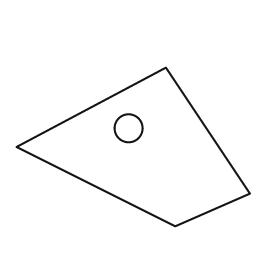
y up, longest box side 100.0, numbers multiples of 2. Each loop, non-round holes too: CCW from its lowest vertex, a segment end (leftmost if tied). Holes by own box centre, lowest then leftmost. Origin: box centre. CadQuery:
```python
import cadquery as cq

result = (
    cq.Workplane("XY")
    .moveTo(18.0, -34.0)
    .lineTo(50.0, -20.0)
    .lineTo(14.0, 34.0)
    .lineTo(-50.0, 0.0)
    .close()
    .moveTo(-2.0, 8.0)
    .circle(6.0)
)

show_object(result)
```